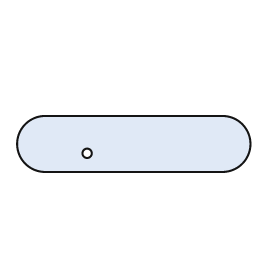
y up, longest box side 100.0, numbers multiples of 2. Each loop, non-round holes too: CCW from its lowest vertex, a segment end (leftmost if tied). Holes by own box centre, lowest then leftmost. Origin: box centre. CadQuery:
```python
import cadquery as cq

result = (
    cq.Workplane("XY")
    .moveTo(-38.0, -12.0)
    .lineTo(38.0, -12.0)
    .threePointArc((50.0, 0.0), (38.0, 12.0))
    .lineTo(-38.0, 12.0)
    .threePointArc((-50.0, 0.0), (-38.0, -12.0))
    .close()
    .moveTo(-20.0, -4.0)
    .circle(2.0)
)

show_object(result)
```